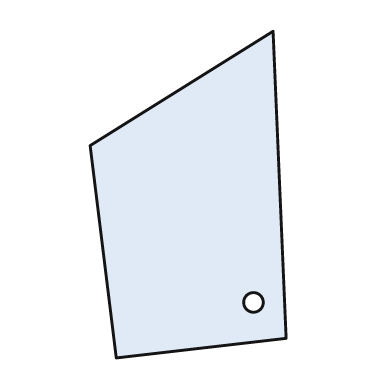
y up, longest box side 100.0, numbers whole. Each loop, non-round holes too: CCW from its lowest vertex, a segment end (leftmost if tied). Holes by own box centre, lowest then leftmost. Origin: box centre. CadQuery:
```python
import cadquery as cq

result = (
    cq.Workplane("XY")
    .moveTo(-22.0, -50.0)
    .lineTo(30.0, -44.0)
    .lineTo(26.0, 50.0)
    .lineTo(-30.0, 15.0)
    .close()
    .moveTo(20.0, -33.0)
    .circle(3.0)
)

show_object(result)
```